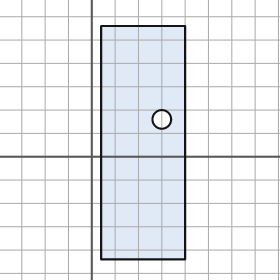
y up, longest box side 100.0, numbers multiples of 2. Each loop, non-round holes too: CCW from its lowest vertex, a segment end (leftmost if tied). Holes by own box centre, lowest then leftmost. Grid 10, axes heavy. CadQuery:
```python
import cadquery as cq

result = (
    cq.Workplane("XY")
    .moveTo(4.0, -44.0)
    .lineTo(40.0, -44.0)
    .lineTo(40.0, 56.0)
    .lineTo(4.0, 56.0)
    .close()
    .moveTo(30.0, 16.0)
    .circle(4.0)
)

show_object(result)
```